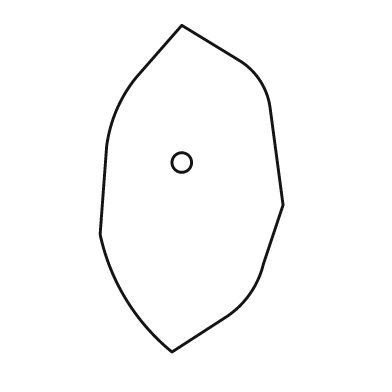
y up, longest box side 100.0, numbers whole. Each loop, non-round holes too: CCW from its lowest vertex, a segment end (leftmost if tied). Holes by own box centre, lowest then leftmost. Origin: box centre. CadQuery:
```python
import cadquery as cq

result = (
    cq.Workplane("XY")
    .moveTo(-6.0, -50.0)
    .lineTo(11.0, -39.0)
    .threePointArc((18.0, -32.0), (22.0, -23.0))
    .lineTo(28.0, -5.0)
    .lineTo(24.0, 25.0)
    .threePointArc((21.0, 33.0), (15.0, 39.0))
    .lineTo(-3.0, 50.0)
    .lineTo(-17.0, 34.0)
    .threePointArc((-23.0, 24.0), (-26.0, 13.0))
    .lineTo(-28.0, -14.0)
    .threePointArc((-20.0, -34.0), (-6.0, -50.0))
    .close()
    .moveTo(-3.0, 8.0)
    .circle(3.0)
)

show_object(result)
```